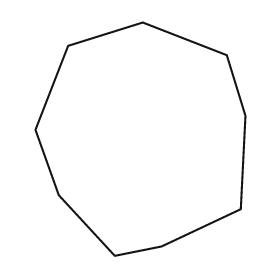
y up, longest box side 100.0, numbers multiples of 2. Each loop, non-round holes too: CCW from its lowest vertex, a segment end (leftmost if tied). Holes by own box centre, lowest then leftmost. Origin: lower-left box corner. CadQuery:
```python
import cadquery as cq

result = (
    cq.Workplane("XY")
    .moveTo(34.0, 0.0)
    .lineTo(54.0, 4.0)
    .lineTo(88.0, 20.0)
    .lineTo(90.0, 60.0)
    .lineTo(82.0, 86.0)
    .lineTo(46.0, 100.0)
    .lineTo(14.0, 90.0)
    .lineTo(0.0, 54.0)
    .lineTo(10.0, 26.0)
    .close()
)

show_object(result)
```